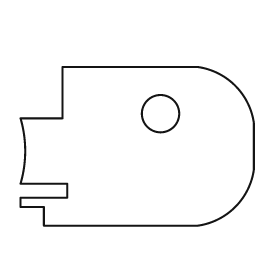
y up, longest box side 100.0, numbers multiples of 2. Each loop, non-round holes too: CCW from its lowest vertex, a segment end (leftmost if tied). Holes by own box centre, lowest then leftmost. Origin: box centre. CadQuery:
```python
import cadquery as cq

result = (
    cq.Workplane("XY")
    .moveTo(-40.0, -34.0)
    .lineTo(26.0, -34.0)
    .threePointArc((42.0, -26.0), (50.0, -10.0))
    .lineTo(50.0, 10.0)
    .threePointArc((42.0, 26.0), (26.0, 34.0))
    .lineTo(-32.0, 34.0)
    .lineTo(-32.0, 12.0)
    .lineTo(-50.0, 12.0)
    .threePointArc((-48.0, -2.0), (-50.0, -16.0))
    .lineTo(-30.0, -16.0)
    .lineTo(-30.0, -22.0)
    .lineTo(-50.0, -22.0)
    .lineTo(-50.0, -26.0)
    .lineTo(-40.0, -26.0)
    .close()
    .moveTo(10.0, 14.0)
    .circle(8.0)
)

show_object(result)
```